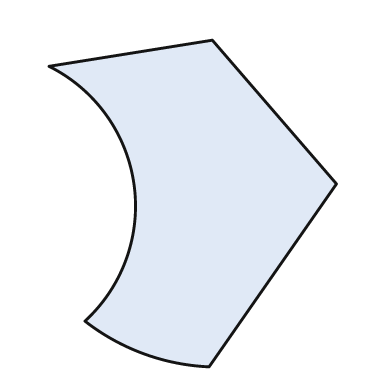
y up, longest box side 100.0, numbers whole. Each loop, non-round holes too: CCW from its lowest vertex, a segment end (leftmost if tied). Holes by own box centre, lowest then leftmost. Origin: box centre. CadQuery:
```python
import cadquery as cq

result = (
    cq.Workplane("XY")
    .moveTo(5.0, -50.0)
    .lineTo(44.0, 6.0)
    .lineTo(6.0, 50.0)
    .lineTo(-44.0, 42.0)
    .threePointArc((-18.0, 6.0), (-33.0, -36.0))
    .threePointArc((-15.0, -46.0), (5.0, -50.0))
    .close()
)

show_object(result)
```